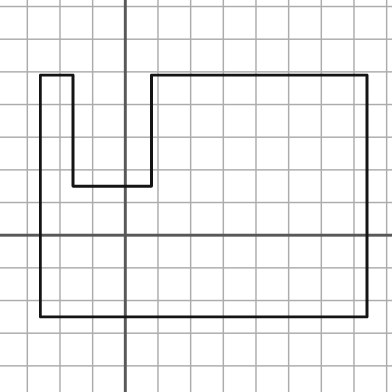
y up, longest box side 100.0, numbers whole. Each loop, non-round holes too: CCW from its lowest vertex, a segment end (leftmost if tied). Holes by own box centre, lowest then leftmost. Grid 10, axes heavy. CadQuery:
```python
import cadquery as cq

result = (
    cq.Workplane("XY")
    .moveTo(-26.0, -25.0)
    .lineTo(74.0, -25.0)
    .lineTo(74.0, 49.0)
    .lineTo(8.0, 49.0)
    .lineTo(8.0, 15.0)
    .lineTo(-16.0, 15.0)
    .lineTo(-16.0, 49.0)
    .lineTo(-26.0, 49.0)
    .close()
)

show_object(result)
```